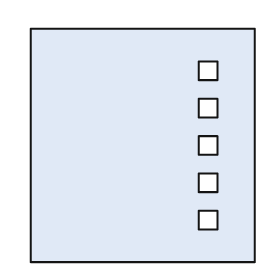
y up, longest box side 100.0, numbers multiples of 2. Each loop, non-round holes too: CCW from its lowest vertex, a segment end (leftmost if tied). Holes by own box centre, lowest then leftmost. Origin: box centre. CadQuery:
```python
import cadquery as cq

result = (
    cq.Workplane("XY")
    .moveTo(-48.0, -50.0)
    .lineTo(48.0, -50.0)
    .lineTo(48.0, 50.0)
    .lineTo(-48.0, 50.0)
    .close()
    .moveTo(24.0, -36.0)
    .lineTo(32.0, -36.0)
    .lineTo(32.0, -28.0)
    .lineTo(24.0, -28.0)
    .close()
    .moveTo(24.0, -20.0)
    .lineTo(32.0, -20.0)
    .lineTo(32.0, -12.0)
    .lineTo(24.0, -12.0)
    .close()
    .moveTo(24.0, -4.0)
    .lineTo(32.0, -4.0)
    .lineTo(32.0, 4.0)
    .lineTo(24.0, 4.0)
    .close()
    .moveTo(24.0, 12.0)
    .lineTo(32.0, 12.0)
    .lineTo(32.0, 20.0)
    .lineTo(24.0, 20.0)
    .close()
    .moveTo(24.0, 28.0)
    .lineTo(32.0, 28.0)
    .lineTo(32.0, 36.0)
    .lineTo(24.0, 36.0)
    .close()
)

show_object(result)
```